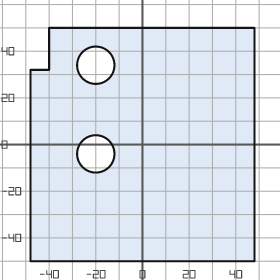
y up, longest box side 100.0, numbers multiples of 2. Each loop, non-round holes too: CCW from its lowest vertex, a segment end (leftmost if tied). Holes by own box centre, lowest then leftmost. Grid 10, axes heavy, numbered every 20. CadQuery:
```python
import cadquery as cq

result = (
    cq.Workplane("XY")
    .moveTo(-48.0, -50.0)
    .lineTo(48.0, -50.0)
    .lineTo(48.0, 50.0)
    .lineTo(-40.0, 50.0)
    .lineTo(-40.0, 32.0)
    .lineTo(-48.0, 32.0)
    .close()
    .moveTo(-20.0, -4.0)
    .circle(8.0)
    .moveTo(-20.0, 34.0)
    .circle(8.0)
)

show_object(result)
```